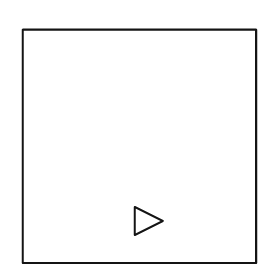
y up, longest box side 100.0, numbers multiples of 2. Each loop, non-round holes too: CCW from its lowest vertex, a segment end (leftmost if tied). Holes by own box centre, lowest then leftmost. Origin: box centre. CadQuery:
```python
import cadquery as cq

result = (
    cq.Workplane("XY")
    .moveTo(-50.0, -50.0)
    .lineTo(50.0, -50.0)
    .lineTo(50.0, 50.0)
    .lineTo(-50.0, 50.0)
    .close()
    .moveTo(-2.0, -38.0)
    .lineTo(10.0, -32.0)
    .lineTo(-2.0, -26.0)
    .close()
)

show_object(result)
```